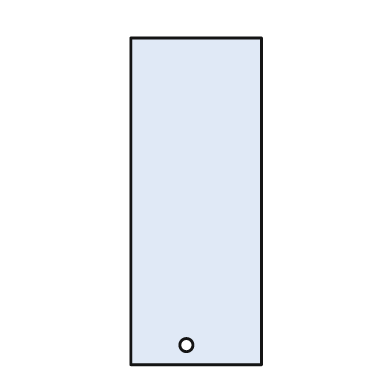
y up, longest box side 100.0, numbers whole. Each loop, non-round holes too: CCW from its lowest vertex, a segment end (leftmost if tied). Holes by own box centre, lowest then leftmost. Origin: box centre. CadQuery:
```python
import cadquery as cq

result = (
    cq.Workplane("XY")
    .moveTo(-20.0, -50.0)
    .lineTo(20.0, -50.0)
    .lineTo(20.0, 50.0)
    .lineTo(-20.0, 50.0)
    .close()
    .moveTo(-3.0, -44.0)
    .circle(2.0)
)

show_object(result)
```